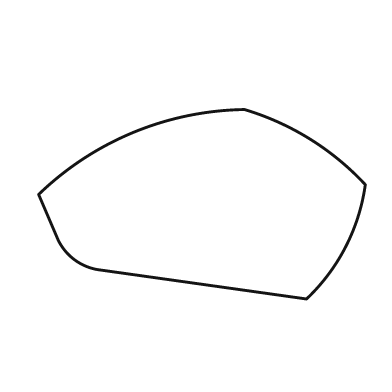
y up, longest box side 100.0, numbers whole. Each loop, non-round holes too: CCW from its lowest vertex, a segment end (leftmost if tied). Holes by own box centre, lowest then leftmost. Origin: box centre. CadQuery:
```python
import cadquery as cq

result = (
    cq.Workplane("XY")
    .moveTo(32.0, -29.0)
    .threePointArc((44.0, -13.0), (50.0, 6.0))
    .threePointArc((33.0, 20.0), (13.0, 29.0))
    .threePointArc((-21.0, 22.0), (-50.0, 3.0))
    .lineTo(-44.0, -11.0)
    .threePointArc((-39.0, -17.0), (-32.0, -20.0))
    .close()
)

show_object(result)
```